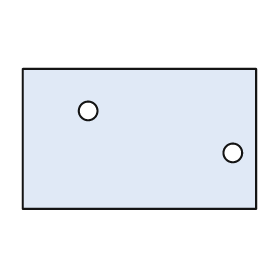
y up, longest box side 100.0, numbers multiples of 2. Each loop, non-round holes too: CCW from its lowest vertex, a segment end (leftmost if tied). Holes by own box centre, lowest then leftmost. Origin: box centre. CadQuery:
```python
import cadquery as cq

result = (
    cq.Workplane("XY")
    .moveTo(-50.0, -30.0)
    .lineTo(50.0, -30.0)
    .lineTo(50.0, 30.0)
    .lineTo(-50.0, 30.0)
    .close()
    .moveTo(40.0, -6.0)
    .circle(4.0)
    .moveTo(-22.0, 12.0)
    .circle(4.0)
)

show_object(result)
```